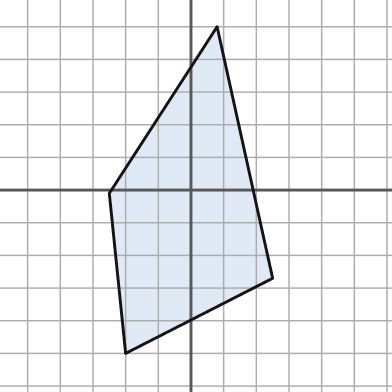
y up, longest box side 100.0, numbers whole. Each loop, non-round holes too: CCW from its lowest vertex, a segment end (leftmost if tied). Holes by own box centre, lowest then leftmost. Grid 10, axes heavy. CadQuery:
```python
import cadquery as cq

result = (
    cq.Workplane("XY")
    .moveTo(-20.0, -50.0)
    .lineTo(25.0, -27.0)
    .lineTo(8.0, 50.0)
    .lineTo(-25.0, -1.0)
    .close()
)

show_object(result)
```